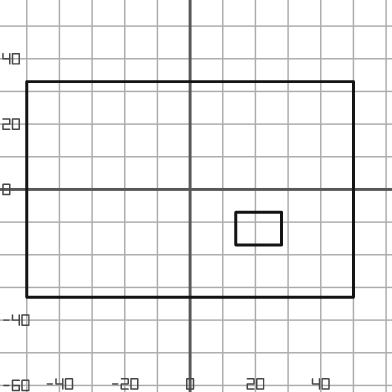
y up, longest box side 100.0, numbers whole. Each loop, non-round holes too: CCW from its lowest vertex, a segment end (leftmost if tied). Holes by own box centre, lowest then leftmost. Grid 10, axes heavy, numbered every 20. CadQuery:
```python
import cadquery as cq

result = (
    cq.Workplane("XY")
    .moveTo(-50.0, -33.0)
    .lineTo(50.0, -33.0)
    .lineTo(50.0, 33.0)
    .lineTo(-50.0, 33.0)
    .close()
    .moveTo(14.0, -17.0)
    .lineTo(28.0, -17.0)
    .lineTo(28.0, -7.0)
    .lineTo(14.0, -7.0)
    .close()
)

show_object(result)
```